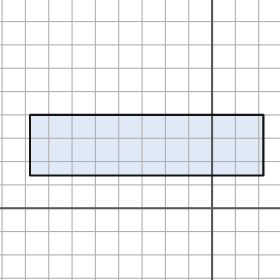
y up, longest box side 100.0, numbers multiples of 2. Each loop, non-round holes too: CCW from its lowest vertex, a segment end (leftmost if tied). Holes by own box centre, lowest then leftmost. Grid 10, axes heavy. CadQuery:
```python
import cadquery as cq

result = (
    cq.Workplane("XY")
    .moveTo(-78.0, 14.0)
    .lineTo(22.0, 14.0)
    .lineTo(22.0, 40.0)
    .lineTo(-78.0, 40.0)
    .close()
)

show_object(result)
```